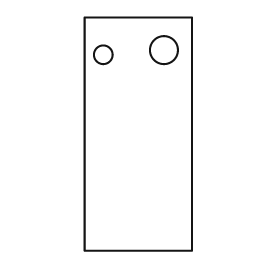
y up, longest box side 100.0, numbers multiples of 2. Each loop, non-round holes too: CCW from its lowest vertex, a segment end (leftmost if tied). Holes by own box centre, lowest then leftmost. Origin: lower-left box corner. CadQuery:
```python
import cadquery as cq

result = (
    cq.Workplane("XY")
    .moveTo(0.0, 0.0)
    .lineTo(46.0, 0.0)
    .lineTo(46.0, 100.0)
    .lineTo(0.0, 100.0)
    .close()
    .moveTo(8.0, 84.0)
    .circle(4.0)
    .moveTo(34.0, 86.0)
    .circle(6.0)
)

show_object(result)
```